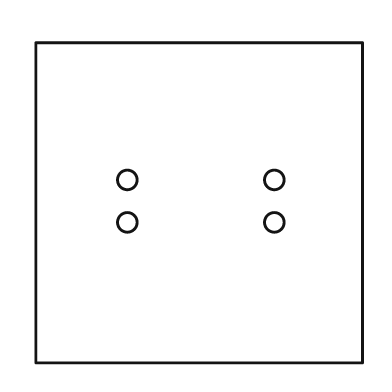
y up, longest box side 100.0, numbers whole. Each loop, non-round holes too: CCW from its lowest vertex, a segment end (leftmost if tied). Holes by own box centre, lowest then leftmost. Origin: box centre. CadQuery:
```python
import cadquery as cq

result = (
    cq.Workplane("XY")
    .moveTo(-50.0, -49.0)
    .lineTo(50.0, -49.0)
    .lineTo(50.0, 49.0)
    .lineTo(-50.0, 49.0)
    .close()
    .moveTo(-22.0, -6.0)
    .circle(3.0)
    .moveTo(23.0, -6.0)
    .circle(3.0)
    .moveTo(-22.0, 7.0)
    .circle(3.0)
    .moveTo(23.0, 7.0)
    .circle(3.0)
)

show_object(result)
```